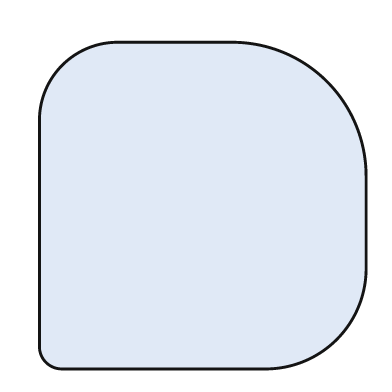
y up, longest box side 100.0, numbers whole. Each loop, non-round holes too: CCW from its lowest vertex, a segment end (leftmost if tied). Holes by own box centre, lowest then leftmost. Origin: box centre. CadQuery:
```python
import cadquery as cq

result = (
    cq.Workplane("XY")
    .moveTo(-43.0, -50.0)
    .lineTo(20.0, -50.0)
    .threePointArc((41.0, -41.0), (50.0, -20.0))
    .lineTo(50.0, 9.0)
    .threePointArc((38.0, 38.0), (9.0, 50.0))
    .lineTo(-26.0, 50.0)
    .threePointArc((-43.0, 43.0), (-50.0, 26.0))
    .lineTo(-50.0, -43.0)
    .threePointArc((-48.0, -48.0), (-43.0, -50.0))
    .close()
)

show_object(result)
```